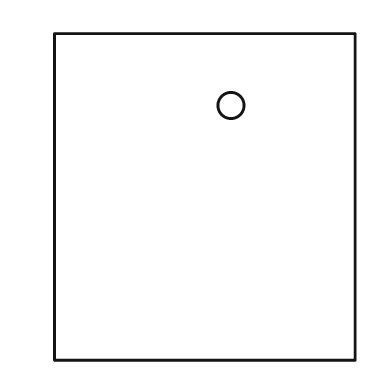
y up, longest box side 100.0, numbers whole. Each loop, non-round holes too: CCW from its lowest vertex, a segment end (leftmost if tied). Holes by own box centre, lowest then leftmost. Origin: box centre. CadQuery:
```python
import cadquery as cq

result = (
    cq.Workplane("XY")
    .moveTo(-46.0, -50.0)
    .lineTo(46.0, -50.0)
    .lineTo(46.0, 50.0)
    .lineTo(-46.0, 50.0)
    .close()
    .moveTo(8.0, 28.0)
    .circle(4.0)
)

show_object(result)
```